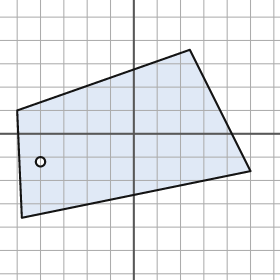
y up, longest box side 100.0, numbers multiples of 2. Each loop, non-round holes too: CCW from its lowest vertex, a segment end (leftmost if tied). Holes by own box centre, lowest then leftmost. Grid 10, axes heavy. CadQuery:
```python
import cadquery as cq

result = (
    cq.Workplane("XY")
    .moveTo(-48.0, -36.0)
    .lineTo(50.0, -16.0)
    .lineTo(24.0, 36.0)
    .lineTo(-50.0, 10.0)
    .close()
    .moveTo(-40.0, -12.0)
    .circle(2.0)
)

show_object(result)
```